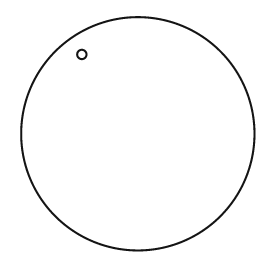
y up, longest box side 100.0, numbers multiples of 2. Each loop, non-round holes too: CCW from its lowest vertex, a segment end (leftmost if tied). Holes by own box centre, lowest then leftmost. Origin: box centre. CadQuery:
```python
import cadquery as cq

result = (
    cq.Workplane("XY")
    .moveTo(0.0, 0.0)
    .circle(50.0)
    .moveTo(-24.0, 34.0)
    .circle(2.0)
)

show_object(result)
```